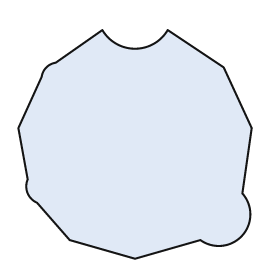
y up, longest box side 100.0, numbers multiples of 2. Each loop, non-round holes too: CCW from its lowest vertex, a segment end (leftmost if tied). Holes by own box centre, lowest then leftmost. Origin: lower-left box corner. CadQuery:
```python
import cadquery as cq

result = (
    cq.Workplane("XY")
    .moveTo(50.0, 0.0)
    .lineTo(78.0, 8.0)
    .threePointArc((96.0, 10.0), (96.0, 28.0))
    .lineTo(100.0, 56.0)
    .lineTo(88.0, 82.0)
    .lineTo(64.0, 98.0)
    .threePointArc((50.0, 90.0), (36.0, 98.0))
    .lineTo(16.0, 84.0)
    .threePointArc((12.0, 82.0), (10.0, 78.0))
    .lineTo(0.0, 56.0)
    .lineTo(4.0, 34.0)
    .threePointArc((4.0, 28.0), (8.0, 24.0))
    .lineTo(22.0, 8.0)
    .close()
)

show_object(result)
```